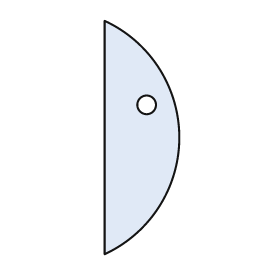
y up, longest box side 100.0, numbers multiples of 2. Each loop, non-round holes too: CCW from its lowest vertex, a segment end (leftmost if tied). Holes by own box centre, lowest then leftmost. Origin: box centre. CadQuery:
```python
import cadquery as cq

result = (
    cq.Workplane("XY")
    .moveTo(-16.0, -50.0)
    .threePointArc((16.0, 0.0), (-16.0, 50.0))
    .close()
    .moveTo(2.0, 14.0)
    .circle(4.0)
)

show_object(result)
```